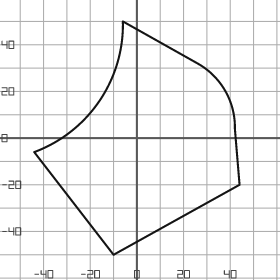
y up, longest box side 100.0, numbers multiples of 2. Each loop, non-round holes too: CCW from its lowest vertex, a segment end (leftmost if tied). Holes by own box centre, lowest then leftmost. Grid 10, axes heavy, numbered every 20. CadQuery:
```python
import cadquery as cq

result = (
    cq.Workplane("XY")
    .moveTo(-10.0, -50.0)
    .lineTo(44.0, -20.0)
    .lineTo(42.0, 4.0)
    .threePointArc((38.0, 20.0), (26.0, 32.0))
    .lineTo(-6.0, 50.0)
    .threePointArc((-16.0, 16.0), (-44.0, -6.0))
    .close()
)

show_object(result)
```